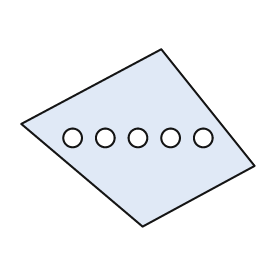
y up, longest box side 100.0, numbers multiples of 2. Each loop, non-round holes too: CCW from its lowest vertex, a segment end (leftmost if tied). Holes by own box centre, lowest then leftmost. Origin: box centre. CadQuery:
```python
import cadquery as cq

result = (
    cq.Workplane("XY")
    .moveTo(2.0, -38.0)
    .lineTo(50.0, -12.0)
    .lineTo(10.0, 38.0)
    .lineTo(-50.0, 6.0)
    .close()
    .moveTo(-28.0, 0.0)
    .circle(4.0)
    .moveTo(-14.0, 0.0)
    .circle(4.0)
    .moveTo(0.0, 0.0)
    .circle(4.0)
    .moveTo(14.0, 0.0)
    .circle(4.0)
    .moveTo(28.0, 0.0)
    .circle(4.0)
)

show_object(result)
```